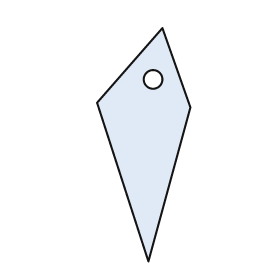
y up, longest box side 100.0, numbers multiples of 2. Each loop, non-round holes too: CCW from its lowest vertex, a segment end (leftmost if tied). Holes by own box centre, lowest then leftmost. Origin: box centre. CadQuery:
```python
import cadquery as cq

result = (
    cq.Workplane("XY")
    .moveTo(2.0, -50.0)
    .lineTo(20.0, 16.0)
    .lineTo(8.0, 50.0)
    .lineTo(-20.0, 18.0)
    .close()
    .moveTo(4.0, 28.0)
    .circle(4.0)
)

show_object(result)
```